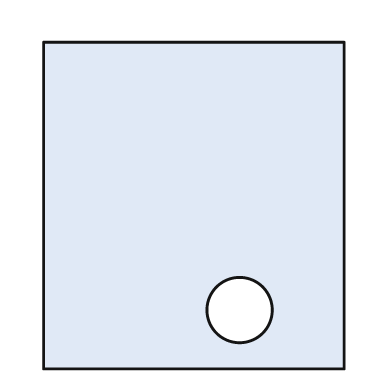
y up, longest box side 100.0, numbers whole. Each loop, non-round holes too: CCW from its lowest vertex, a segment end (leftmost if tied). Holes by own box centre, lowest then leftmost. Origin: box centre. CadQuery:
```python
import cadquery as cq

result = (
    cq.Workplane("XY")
    .moveTo(-46.0, -50.0)
    .lineTo(46.0, -50.0)
    .lineTo(46.0, 50.0)
    .lineTo(-46.0, 50.0)
    .close()
    .moveTo(14.0, -32.0)
    .circle(10.0)
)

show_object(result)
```